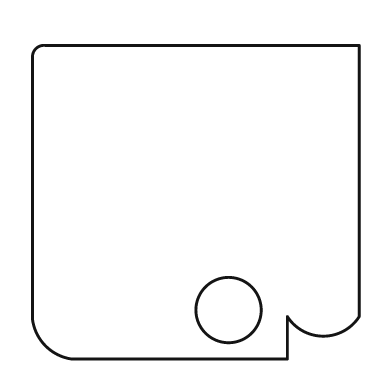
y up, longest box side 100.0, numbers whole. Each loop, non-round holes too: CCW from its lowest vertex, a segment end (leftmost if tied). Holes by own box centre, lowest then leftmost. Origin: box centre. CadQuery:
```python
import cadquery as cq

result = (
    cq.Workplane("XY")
    .moveTo(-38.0, -48.0)
    .lineTo(28.0, -48.0)
    .lineTo(28.0, -35.0)
    .threePointArc((39.0, -41.0), (50.0, -35.0))
    .lineTo(50.0, 48.0)
    .lineTo(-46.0, 48.0)
    .threePointArc((-49.0, 47.0), (-50.0, 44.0))
    .lineTo(-50.0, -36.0)
    .threePointArc((-46.0, -44.0), (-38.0, -48.0))
    .close()
    .moveTo(10.0, -33.0)
    .circle(10.0)
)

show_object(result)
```